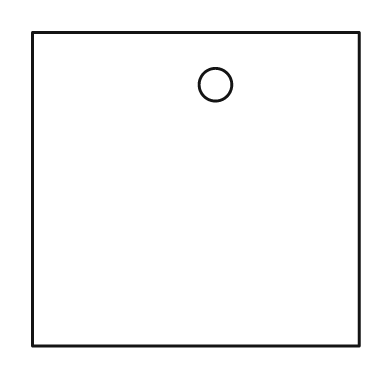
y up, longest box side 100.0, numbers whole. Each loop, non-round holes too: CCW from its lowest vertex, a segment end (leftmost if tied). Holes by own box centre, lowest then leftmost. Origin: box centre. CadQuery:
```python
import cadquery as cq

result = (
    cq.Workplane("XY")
    .moveTo(-50.0, -48.0)
    .lineTo(50.0, -48.0)
    .lineTo(50.0, 48.0)
    .lineTo(-50.0, 48.0)
    .close()
    .moveTo(6.0, 32.0)
    .circle(5.0)
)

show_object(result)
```